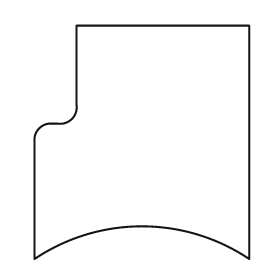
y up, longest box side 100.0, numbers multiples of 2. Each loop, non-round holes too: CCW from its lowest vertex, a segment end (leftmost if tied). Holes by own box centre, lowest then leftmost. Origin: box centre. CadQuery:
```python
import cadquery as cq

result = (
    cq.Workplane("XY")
    .moveTo(-46.0, -50.0)
    .threePointArc((0.0, -36.0), (46.0, -50.0))
    .lineTo(46.0, 50.0)
    .lineTo(-28.0, 50.0)
    .lineTo(-28.0, 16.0)
    .threePointArc((-30.0, 10.0), (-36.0, 8.0))
    .lineTo(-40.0, 8.0)
    .threePointArc((-44.0, 6.0), (-46.0, 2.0))
    .close()
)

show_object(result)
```